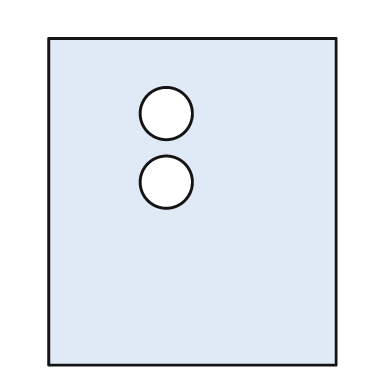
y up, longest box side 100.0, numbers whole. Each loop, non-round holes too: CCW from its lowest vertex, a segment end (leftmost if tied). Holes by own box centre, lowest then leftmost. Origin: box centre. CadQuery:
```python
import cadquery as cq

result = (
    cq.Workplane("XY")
    .moveTo(-44.0, -50.0)
    .lineTo(44.0, -50.0)
    .lineTo(44.0, 50.0)
    .lineTo(-44.0, 50.0)
    .close()
    .moveTo(-8.0, 6.0)
    .circle(8.0)
    .moveTo(-8.0, 27.0)
    .circle(8.0)
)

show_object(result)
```